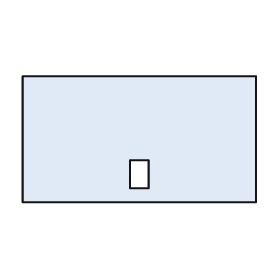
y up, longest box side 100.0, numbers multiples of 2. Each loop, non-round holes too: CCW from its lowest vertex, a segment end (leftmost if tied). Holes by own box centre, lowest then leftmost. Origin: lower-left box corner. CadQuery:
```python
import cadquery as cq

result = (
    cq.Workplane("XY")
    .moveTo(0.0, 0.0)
    .lineTo(100.0, 0.0)
    .lineTo(100.0, 54.0)
    .lineTo(0.0, 54.0)
    .close()
    .moveTo(46.0, 6.0)
    .lineTo(54.0, 6.0)
    .lineTo(54.0, 18.0)
    .lineTo(46.0, 18.0)
    .close()
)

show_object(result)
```